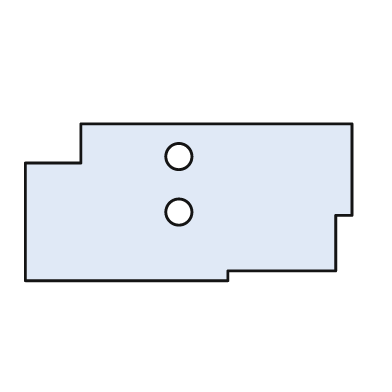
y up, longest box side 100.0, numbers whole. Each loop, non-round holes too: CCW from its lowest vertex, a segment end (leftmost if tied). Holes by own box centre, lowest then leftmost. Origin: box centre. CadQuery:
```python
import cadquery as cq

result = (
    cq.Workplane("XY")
    .moveTo(-50.0, -24.0)
    .lineTo(12.0, -24.0)
    .lineTo(12.0, -21.0)
    .lineTo(45.0, -21.0)
    .lineTo(45.0, -4.0)
    .lineTo(50.0, -4.0)
    .lineTo(50.0, 24.0)
    .lineTo(-33.0, 24.0)
    .lineTo(-33.0, 12.0)
    .lineTo(-50.0, 12.0)
    .close()
    .moveTo(-3.0, -3.0)
    .circle(4.0)
    .moveTo(-3.0, 14.0)
    .circle(4.0)
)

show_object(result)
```